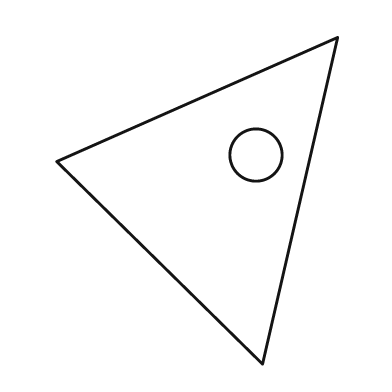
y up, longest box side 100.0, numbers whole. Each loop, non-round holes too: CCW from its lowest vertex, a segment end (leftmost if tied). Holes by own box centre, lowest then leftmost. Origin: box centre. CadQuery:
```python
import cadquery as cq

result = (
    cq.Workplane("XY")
    .moveTo(20.0, -50.0)
    .lineTo(43.0, 50.0)
    .lineTo(-43.0, 12.0)
    .close()
    .moveTo(18.0, 14.0)
    .circle(8.0)
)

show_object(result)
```